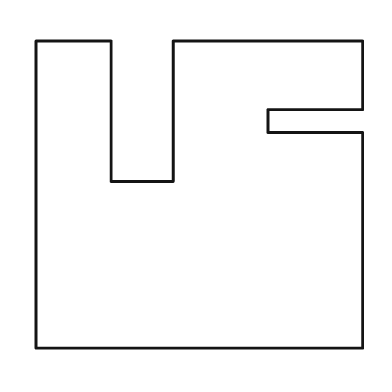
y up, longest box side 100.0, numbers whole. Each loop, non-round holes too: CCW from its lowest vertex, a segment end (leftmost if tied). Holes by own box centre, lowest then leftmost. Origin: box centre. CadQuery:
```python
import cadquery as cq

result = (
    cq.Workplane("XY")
    .moveTo(-50.0, -47.0)
    .lineTo(50.0, -47.0)
    .lineTo(50.0, 19.0)
    .lineTo(21.0, 19.0)
    .lineTo(21.0, 26.0)
    .lineTo(50.0, 26.0)
    .lineTo(50.0, 47.0)
    .lineTo(-8.0, 47.0)
    .lineTo(-8.0, 4.0)
    .lineTo(-27.0, 4.0)
    .lineTo(-27.0, 47.0)
    .lineTo(-50.0, 47.0)
    .close()
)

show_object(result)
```